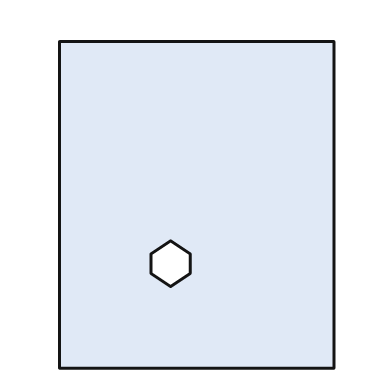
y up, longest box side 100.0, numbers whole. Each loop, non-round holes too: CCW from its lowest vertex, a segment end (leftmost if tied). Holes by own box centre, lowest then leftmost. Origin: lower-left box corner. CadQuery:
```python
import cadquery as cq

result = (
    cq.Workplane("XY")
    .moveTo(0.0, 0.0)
    .lineTo(84.0, 0.0)
    .lineTo(84.0, 100.0)
    .lineTo(0.0, 100.0)
    .close()
    .moveTo(34.0, 25.0)
    .lineTo(40.0, 29.0)
    .lineTo(40.0, 35.0)
    .lineTo(34.0, 39.0)
    .lineTo(28.0, 35.0)
    .lineTo(28.0, 29.0)
    .close()
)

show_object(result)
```